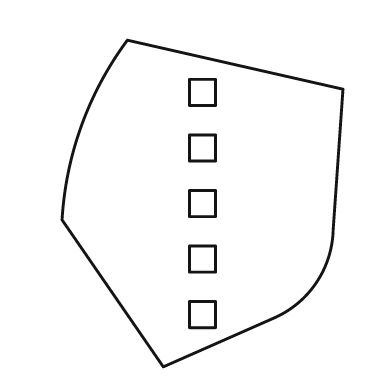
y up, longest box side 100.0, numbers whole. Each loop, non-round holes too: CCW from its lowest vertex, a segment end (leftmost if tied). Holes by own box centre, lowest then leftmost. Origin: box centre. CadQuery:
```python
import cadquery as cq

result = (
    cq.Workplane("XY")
    .moveTo(-12.0, -50.0)
    .lineTo(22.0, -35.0)
    .threePointArc((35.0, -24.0), (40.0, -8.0))
    .lineTo(43.0, 35.0)
    .lineTo(-23.0, 50.0)
    .threePointArc((-37.0, 24.0), (-43.0, -5.0))
    .close()
    .moveTo(-4.0, -38.0)
    .lineTo(4.0, -38.0)
    .lineTo(4.0, -30.0)
    .lineTo(-4.0, -30.0)
    .close()
    .moveTo(-4.0, -21.0)
    .lineTo(4.0, -21.0)
    .lineTo(4.0, -13.0)
    .lineTo(-4.0, -13.0)
    .close()
    .moveTo(-4.0, -4.0)
    .lineTo(4.0, -4.0)
    .lineTo(4.0, 4.0)
    .lineTo(-4.0, 4.0)
    .close()
    .moveTo(-4.0, 13.0)
    .lineTo(4.0, 13.0)
    .lineTo(4.0, 21.0)
    .lineTo(-4.0, 21.0)
    .close()
    .moveTo(-4.0, 30.0)
    .lineTo(4.0, 30.0)
    .lineTo(4.0, 38.0)
    .lineTo(-4.0, 38.0)
    .close()
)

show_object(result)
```